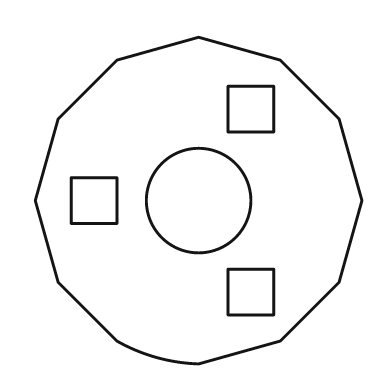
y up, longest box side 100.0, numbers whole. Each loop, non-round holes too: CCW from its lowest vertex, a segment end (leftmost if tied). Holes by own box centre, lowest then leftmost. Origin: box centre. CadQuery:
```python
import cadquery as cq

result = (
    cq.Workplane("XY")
    .moveTo(0.0, -50.0)
    .lineTo(25.0, -43.0)
    .lineTo(43.0, -25.0)
    .lineTo(50.0, 0.0)
    .lineTo(43.0, 25.0)
    .lineTo(25.0, 43.0)
    .lineTo(0.0, 50.0)
    .lineTo(-25.0, 43.0)
    .lineTo(-43.0, 25.0)
    .lineTo(-50.0, 0.0)
    .lineTo(-43.0, -25.0)
    .lineTo(-25.0, -43.0)
    .threePointArc((-13.0, -48.0), (0.0, -50.0))
    .close()
    .moveTo(9.0, -35.0)
    .lineTo(23.0, -35.0)
    .lineTo(23.0, -21.0)
    .lineTo(9.0, -21.0)
    .close()
    .moveTo(-39.0, -7.0)
    .lineTo(-25.0, -7.0)
    .lineTo(-25.0, 7.0)
    .lineTo(-39.0, 7.0)
    .close()
    .moveTo(0.0, 0.0)
    .circle(16.0)
    .moveTo(9.0, 21.0)
    .lineTo(23.0, 21.0)
    .lineTo(23.0, 35.0)
    .lineTo(9.0, 35.0)
    .close()
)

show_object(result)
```